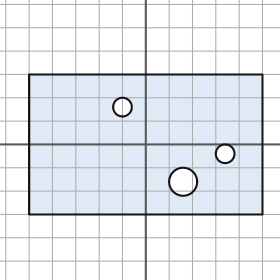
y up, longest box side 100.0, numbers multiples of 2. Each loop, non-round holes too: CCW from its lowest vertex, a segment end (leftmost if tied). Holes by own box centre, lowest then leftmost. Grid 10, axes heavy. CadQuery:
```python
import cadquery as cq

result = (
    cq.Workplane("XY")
    .moveTo(-50.0, -30.0)
    .lineTo(50.0, -30.0)
    .lineTo(50.0, 30.0)
    .lineTo(-50.0, 30.0)
    .close()
    .moveTo(16.0, -16.0)
    .circle(6.0)
    .moveTo(34.0, -4.0)
    .circle(4.0)
    .moveTo(-10.0, 16.0)
    .circle(4.0)
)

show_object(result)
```